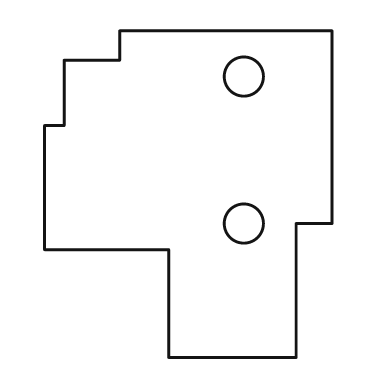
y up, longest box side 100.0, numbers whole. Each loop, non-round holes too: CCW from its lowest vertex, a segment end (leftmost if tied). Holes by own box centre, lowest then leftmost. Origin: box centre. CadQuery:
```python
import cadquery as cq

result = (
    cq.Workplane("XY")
    .moveTo(-6.0, -50.0)
    .lineTo(33.0, -50.0)
    .lineTo(33.0, -9.0)
    .lineTo(44.0, -9.0)
    .lineTo(44.0, 50.0)
    .lineTo(-21.0, 50.0)
    .lineTo(-21.0, 41.0)
    .lineTo(-38.0, 41.0)
    .lineTo(-38.0, 21.0)
    .lineTo(-44.0, 21.0)
    .lineTo(-44.0, -17.0)
    .lineTo(-6.0, -17.0)
    .close()
    .moveTo(17.0, -9.0)
    .circle(6.0)
    .moveTo(17.0, 36.0)
    .circle(6.0)
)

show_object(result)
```